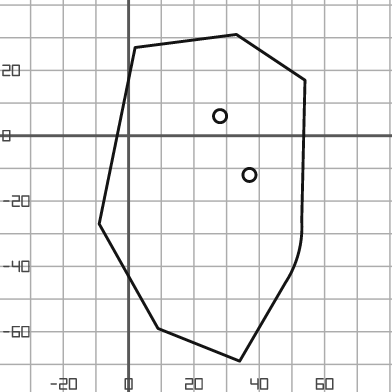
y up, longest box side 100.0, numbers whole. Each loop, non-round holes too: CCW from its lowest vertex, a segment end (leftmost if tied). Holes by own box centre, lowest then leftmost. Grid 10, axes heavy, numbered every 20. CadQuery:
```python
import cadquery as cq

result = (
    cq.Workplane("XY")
    .moveTo(34.0, -69.0)
    .lineTo(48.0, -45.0)
    .threePointArc((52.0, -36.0), (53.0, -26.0))
    .lineTo(54.0, 17.0)
    .lineTo(33.0, 31.0)
    .lineTo(2.0, 27.0)
    .lineTo(-9.0, -27.0)
    .lineTo(9.0, -59.0)
    .close()
    .moveTo(37.0, -12.0)
    .circle(2.0)
    .moveTo(28.0, 6.0)
    .circle(2.0)
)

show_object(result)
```